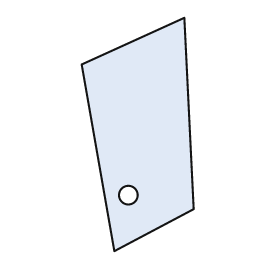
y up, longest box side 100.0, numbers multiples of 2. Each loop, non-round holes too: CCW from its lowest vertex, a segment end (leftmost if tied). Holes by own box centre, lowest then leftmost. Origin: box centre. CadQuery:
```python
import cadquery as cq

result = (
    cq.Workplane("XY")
    .moveTo(-10.0, -50.0)
    .lineTo(24.0, -32.0)
    .lineTo(20.0, 50.0)
    .lineTo(-24.0, 30.0)
    .close()
    .moveTo(-4.0, -26.0)
    .circle(4.0)
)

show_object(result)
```